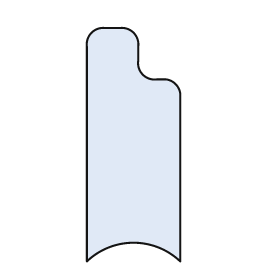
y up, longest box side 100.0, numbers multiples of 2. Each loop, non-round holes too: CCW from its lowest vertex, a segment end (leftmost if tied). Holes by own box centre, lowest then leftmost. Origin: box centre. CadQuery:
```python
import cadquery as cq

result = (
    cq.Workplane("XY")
    .moveTo(-20.0, -50.0)
    .threePointArc((0.0, -42.0), (20.0, -50.0))
    .lineTo(20.0, 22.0)
    .threePointArc((18.0, 26.0), (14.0, 28.0))
    .lineTo(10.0, 28.0)
    .threePointArc((4.0, 30.0), (2.0, 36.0))
    .lineTo(2.0, 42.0)
    .threePointArc((0.0, 48.0), (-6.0, 50.0))
    .lineTo(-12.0, 50.0)
    .threePointArc((-18.0, 48.0), (-20.0, 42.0))
    .close()
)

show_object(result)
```